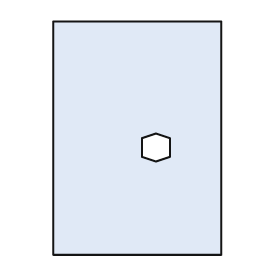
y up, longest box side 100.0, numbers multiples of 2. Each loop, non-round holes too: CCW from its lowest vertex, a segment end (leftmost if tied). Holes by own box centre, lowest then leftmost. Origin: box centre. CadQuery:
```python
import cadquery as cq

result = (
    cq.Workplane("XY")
    .moveTo(-36.0, -50.0)
    .lineTo(36.0, -50.0)
    .lineTo(36.0, 50.0)
    .lineTo(-36.0, 50.0)
    .close()
    .moveTo(8.0, -10.0)
    .lineTo(14.0, -8.0)
    .lineTo(14.0, 0.0)
    .lineTo(8.0, 2.0)
    .lineTo(2.0, 0.0)
    .lineTo(2.0, -8.0)
    .close()
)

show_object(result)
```